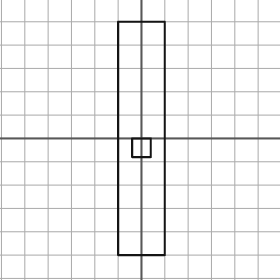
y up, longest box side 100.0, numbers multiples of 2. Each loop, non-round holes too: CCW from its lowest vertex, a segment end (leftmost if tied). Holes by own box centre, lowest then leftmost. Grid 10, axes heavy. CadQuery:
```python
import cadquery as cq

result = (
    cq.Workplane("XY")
    .moveTo(-10.0, -50.0)
    .lineTo(10.0, -50.0)
    .lineTo(10.0, 50.0)
    .lineTo(-10.0, 50.0)
    .close()
    .moveTo(-4.0, -8.0)
    .lineTo(4.0, -8.0)
    .lineTo(4.0, 0.0)
    .lineTo(-4.0, 0.0)
    .close()
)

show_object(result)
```